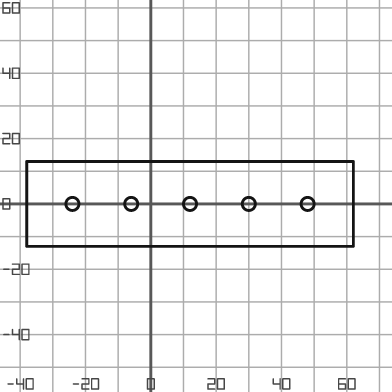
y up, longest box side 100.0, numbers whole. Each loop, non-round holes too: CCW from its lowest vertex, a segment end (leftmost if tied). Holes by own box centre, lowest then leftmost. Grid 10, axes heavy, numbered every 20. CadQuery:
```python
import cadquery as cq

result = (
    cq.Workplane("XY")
    .moveTo(-38.0, -13.0)
    .lineTo(62.0, -13.0)
    .lineTo(62.0, 13.0)
    .lineTo(-38.0, 13.0)
    .close()
    .moveTo(-24.0, 0.0)
    .circle(2.0)
    .moveTo(-6.0, 0.0)
    .circle(2.0)
    .moveTo(12.0, 0.0)
    .circle(2.0)
    .moveTo(30.0, 0.0)
    .circle(2.0)
    .moveTo(48.0, 0.0)
    .circle(2.0)
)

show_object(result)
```